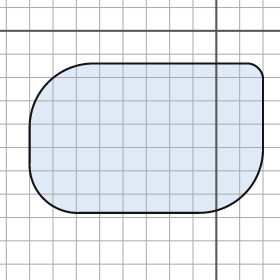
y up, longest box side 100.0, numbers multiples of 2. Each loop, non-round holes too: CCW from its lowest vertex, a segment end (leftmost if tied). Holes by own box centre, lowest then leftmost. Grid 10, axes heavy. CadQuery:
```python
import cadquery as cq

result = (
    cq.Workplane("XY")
    .moveTo(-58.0, -78.0)
    .lineTo(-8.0, -78.0)
    .threePointArc((12.0, -70.0), (20.0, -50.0))
    .lineTo(20.0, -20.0)
    .threePointArc((18.0, -16.0), (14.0, -14.0))
    .lineTo(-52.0, -14.0)
    .threePointArc((-72.0, -22.0), (-80.0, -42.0))
    .lineTo(-80.0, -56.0)
    .threePointArc((-74.0, -72.0), (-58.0, -78.0))
    .close()
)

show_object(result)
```